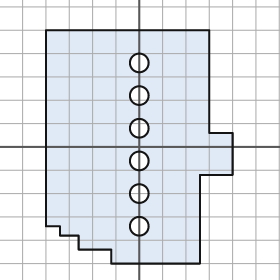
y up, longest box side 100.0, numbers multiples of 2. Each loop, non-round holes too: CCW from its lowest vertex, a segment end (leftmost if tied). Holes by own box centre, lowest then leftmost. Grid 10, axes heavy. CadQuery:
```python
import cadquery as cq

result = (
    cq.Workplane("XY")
    .moveTo(-12.0, -50.0)
    .lineTo(26.0, -50.0)
    .lineTo(26.0, -12.0)
    .lineTo(40.0, -12.0)
    .lineTo(40.0, 6.0)
    .lineTo(30.0, 6.0)
    .lineTo(30.0, 50.0)
    .lineTo(-40.0, 50.0)
    .lineTo(-40.0, -34.0)
    .lineTo(-34.0, -34.0)
    .lineTo(-34.0, -38.0)
    .lineTo(-26.0, -38.0)
    .lineTo(-26.0, -44.0)
    .lineTo(-12.0, -44.0)
    .close()
    .moveTo(0.0, -34.0)
    .circle(4.0)
    .moveTo(0.0, -20.0)
    .circle(4.0)
    .moveTo(0.0, -6.0)
    .circle(4.0)
    .moveTo(0.0, 8.0)
    .circle(4.0)
    .moveTo(0.0, 22.0)
    .circle(4.0)
    .moveTo(0.0, 36.0)
    .circle(4.0)
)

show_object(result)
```